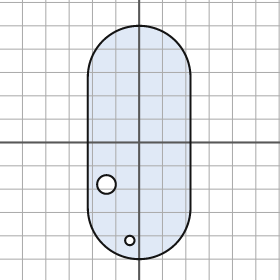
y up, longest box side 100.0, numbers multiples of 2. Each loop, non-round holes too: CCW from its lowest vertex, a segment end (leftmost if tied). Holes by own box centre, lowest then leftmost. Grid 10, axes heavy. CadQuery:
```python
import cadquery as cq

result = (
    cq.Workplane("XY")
    .moveTo(-22.0, -28.0)
    .threePointArc((0.0, -50.0), (22.0, -28.0))
    .lineTo(22.0, 28.0)
    .threePointArc((0.0, 50.0), (-22.0, 28.0))
    .close()
    .moveTo(-4.0, -42.0)
    .circle(2.0)
    .moveTo(-14.0, -18.0)
    .circle(4.0)
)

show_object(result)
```